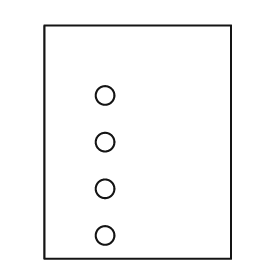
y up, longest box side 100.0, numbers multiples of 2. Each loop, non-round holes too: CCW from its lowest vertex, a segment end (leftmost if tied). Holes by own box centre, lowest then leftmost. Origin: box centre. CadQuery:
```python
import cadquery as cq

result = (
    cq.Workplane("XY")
    .moveTo(-40.0, -50.0)
    .lineTo(40.0, -50.0)
    .lineTo(40.0, 50.0)
    .lineTo(-40.0, 50.0)
    .close()
    .moveTo(-14.0, -40.0)
    .circle(4.0)
    .moveTo(-14.0, -20.0)
    .circle(4.0)
    .moveTo(-14.0, 0.0)
    .circle(4.0)
    .moveTo(-14.0, 20.0)
    .circle(4.0)
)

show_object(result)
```